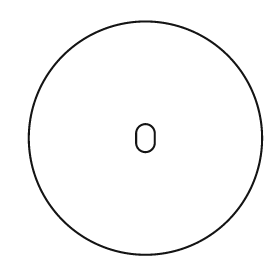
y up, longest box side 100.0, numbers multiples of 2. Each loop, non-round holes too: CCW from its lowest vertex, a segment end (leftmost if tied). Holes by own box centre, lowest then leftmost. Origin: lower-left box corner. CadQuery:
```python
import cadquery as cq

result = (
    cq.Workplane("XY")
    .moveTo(50.0, 50.0)
    .circle(50.0)
    .moveTo(46.0, 48.0)
    .threePointArc((50.0, 44.0), (54.0, 48.0))
    .lineTo(54.0, 52.0)
    .threePointArc((50.0, 56.0), (46.0, 52.0))
    .close()
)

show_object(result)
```